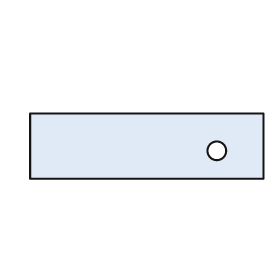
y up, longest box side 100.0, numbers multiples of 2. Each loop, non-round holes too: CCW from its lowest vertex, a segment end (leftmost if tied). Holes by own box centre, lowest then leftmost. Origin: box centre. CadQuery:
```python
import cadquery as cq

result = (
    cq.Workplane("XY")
    .moveTo(-50.0, -14.0)
    .lineTo(50.0, -14.0)
    .lineTo(50.0, 14.0)
    .lineTo(-50.0, 14.0)
    .close()
    .moveTo(30.0, -2.0)
    .circle(4.0)
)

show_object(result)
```